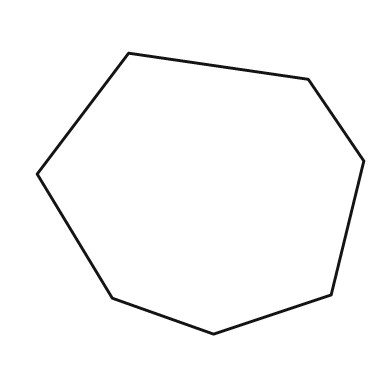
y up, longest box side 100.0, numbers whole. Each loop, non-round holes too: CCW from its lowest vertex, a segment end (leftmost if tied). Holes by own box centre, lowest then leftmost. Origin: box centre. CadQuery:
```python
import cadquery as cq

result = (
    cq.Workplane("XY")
    .moveTo(4.0, -43.0)
    .lineTo(40.0, -31.0)
    .lineTo(50.0, 10.0)
    .lineTo(33.0, 35.0)
    .lineTo(-22.0, 43.0)
    .lineTo(-50.0, 6.0)
    .lineTo(-27.0, -32.0)
    .close()
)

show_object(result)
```